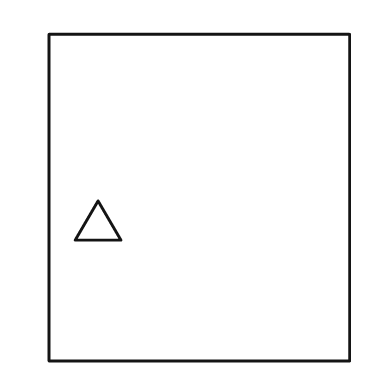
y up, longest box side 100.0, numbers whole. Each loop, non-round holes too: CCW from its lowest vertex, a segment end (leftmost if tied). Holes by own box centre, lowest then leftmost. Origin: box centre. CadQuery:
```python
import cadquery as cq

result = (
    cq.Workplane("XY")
    .moveTo(-46.0, -50.0)
    .lineTo(46.0, -50.0)
    .lineTo(46.0, 50.0)
    .lineTo(-46.0, 50.0)
    .close()
    .moveTo(-38.0, -13.0)
    .lineTo(-24.0, -13.0)
    .lineTo(-31.0, -1.0)
    .close()
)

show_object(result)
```